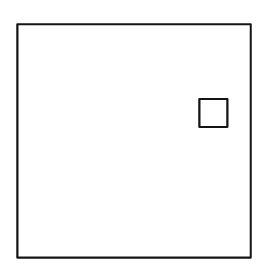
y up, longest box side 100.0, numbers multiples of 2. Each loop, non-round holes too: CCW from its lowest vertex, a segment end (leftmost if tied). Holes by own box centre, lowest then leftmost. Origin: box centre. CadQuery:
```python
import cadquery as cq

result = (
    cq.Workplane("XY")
    .moveTo(-50.0, -50.0)
    .lineTo(50.0, -50.0)
    .lineTo(50.0, 50.0)
    .lineTo(-50.0, 50.0)
    .close()
    .moveTo(28.0, 6.0)
    .lineTo(40.0, 6.0)
    .lineTo(40.0, 18.0)
    .lineTo(28.0, 18.0)
    .close()
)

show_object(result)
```